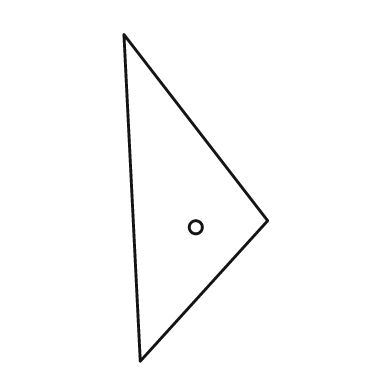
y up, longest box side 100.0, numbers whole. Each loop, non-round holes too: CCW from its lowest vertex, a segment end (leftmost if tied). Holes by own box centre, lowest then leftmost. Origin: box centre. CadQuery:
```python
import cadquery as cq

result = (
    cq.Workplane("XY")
    .moveTo(-17.0, -50.0)
    .lineTo(22.0, -7.0)
    .lineTo(-22.0, 50.0)
    .close()
    .moveTo(0.0, -9.0)
    .circle(2.0)
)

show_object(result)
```